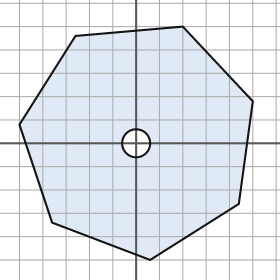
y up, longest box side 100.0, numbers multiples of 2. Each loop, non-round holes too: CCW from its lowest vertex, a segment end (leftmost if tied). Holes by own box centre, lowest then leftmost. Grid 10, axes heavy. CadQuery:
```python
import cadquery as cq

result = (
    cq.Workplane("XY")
    .moveTo(6.0, -50.0)
    .lineTo(44.0, -26.0)
    .lineTo(50.0, 18.0)
    .lineTo(20.0, 50.0)
    .lineTo(-26.0, 46.0)
    .lineTo(-50.0, 8.0)
    .lineTo(-36.0, -34.0)
    .close()
    .moveTo(0.0, 0.0)
    .circle(6.0)
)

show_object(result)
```